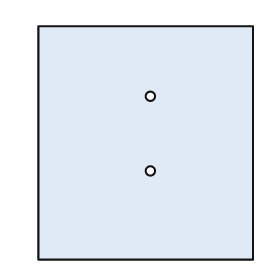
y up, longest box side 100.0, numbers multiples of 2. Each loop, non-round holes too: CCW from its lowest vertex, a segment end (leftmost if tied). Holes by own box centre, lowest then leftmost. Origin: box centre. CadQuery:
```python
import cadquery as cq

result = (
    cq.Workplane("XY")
    .moveTo(-46.0, -50.0)
    .lineTo(46.0, -50.0)
    .lineTo(46.0, 50.0)
    .lineTo(-46.0, 50.0)
    .close()
    .moveTo(2.0, -12.0)
    .circle(2.0)
    .moveTo(2.0, 20.0)
    .circle(2.0)
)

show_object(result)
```